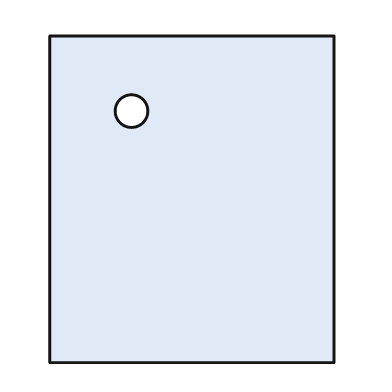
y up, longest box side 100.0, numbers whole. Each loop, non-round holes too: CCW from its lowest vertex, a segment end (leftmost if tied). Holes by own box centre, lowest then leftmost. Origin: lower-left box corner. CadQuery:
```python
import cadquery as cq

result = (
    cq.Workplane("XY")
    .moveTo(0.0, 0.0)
    .lineTo(87.0, 0.0)
    .lineTo(87.0, 100.0)
    .lineTo(0.0, 100.0)
    .close()
    .moveTo(25.0, 77.0)
    .circle(5.0)
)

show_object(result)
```